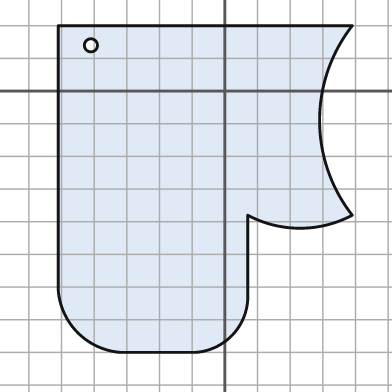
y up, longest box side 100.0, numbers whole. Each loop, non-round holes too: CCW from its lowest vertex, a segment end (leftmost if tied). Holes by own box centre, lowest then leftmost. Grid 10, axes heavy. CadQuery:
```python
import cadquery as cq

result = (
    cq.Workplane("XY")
    .moveTo(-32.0, -80.0)
    .lineTo(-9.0, -80.0)
    .threePointArc((2.0, -75.0), (7.0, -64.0))
    .lineTo(7.0, -38.0)
    .threePointArc((23.0, -42.0), (39.0, -38.0))
    .threePointArc((29.0, -9.0), (39.0, 20.0))
    .lineTo(-51.0, 20.0)
    .lineTo(-51.0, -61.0)
    .threePointArc((-45.0, -74.0), (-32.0, -80.0))
    .close()
    .moveTo(-41.0, 14.0)
    .circle(2.0)
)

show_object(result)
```